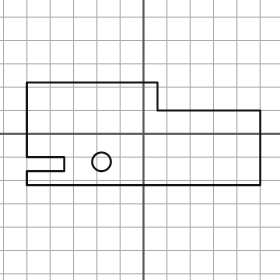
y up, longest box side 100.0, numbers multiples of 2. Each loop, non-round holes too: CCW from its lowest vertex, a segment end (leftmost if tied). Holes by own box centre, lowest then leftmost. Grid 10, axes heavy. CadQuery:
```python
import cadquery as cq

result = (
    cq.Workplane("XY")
    .moveTo(-50.0, -22.0)
    .lineTo(50.0, -22.0)
    .lineTo(50.0, 10.0)
    .lineTo(6.0, 10.0)
    .lineTo(6.0, 22.0)
    .lineTo(-50.0, 22.0)
    .lineTo(-50.0, -10.0)
    .lineTo(-34.0, -10.0)
    .lineTo(-34.0, -16.0)
    .lineTo(-50.0, -16.0)
    .close()
    .moveTo(-18.0, -12.0)
    .circle(4.0)
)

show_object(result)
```